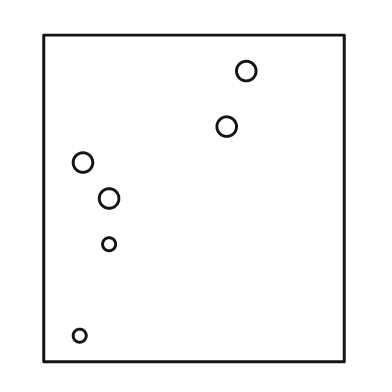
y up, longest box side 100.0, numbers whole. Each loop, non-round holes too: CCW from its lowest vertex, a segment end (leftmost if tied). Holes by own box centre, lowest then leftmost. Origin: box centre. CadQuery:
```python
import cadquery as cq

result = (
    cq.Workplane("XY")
    .moveTo(-46.0, -50.0)
    .lineTo(46.0, -50.0)
    .lineTo(46.0, 50.0)
    .lineTo(-46.0, 50.0)
    .close()
    .moveTo(-35.0, -42.0)
    .circle(2.0)
    .moveTo(-26.0, -14.0)
    .circle(2.0)
    .moveTo(-26.0, 0.0)
    .circle(3.0)
    .moveTo(-34.0, 11.0)
    .circle(3.0)
    .moveTo(10.0, 22.0)
    .circle(3.0)
    .moveTo(16.0, 39.0)
    .circle(3.0)
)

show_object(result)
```